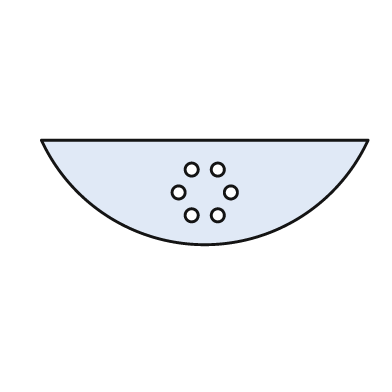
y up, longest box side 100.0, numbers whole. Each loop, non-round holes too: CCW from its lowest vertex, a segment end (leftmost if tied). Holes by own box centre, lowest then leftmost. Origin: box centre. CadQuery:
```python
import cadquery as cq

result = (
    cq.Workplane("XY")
    .moveTo(-50.0, 16.0)
    .threePointArc((0.0, -16.0), (50.0, 16.0))
    .close()
    .moveTo(-4.0, -7.0)
    .circle(2.0)
    .moveTo(4.0, -7.0)
    .circle(2.0)
    .moveTo(-8.0, 0.0)
    .circle(2.0)
    .moveTo(8.0, 0.0)
    .circle(2.0)
    .moveTo(-4.0, 7.0)
    .circle(2.0)
    .moveTo(4.0, 7.0)
    .circle(2.0)
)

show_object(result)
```